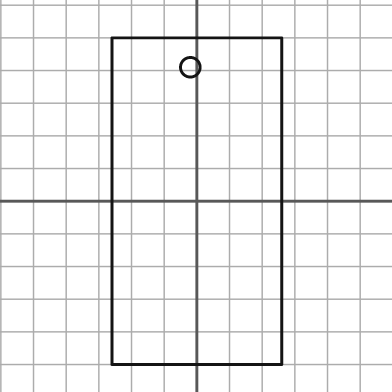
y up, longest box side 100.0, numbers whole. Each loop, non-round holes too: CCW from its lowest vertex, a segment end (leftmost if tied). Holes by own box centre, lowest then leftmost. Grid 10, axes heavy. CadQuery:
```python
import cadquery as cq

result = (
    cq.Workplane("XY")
    .moveTo(-26.0, -50.0)
    .lineTo(26.0, -50.0)
    .lineTo(26.0, 50.0)
    .lineTo(-26.0, 50.0)
    .close()
    .moveTo(-2.0, 41.0)
    .circle(3.0)
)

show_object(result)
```